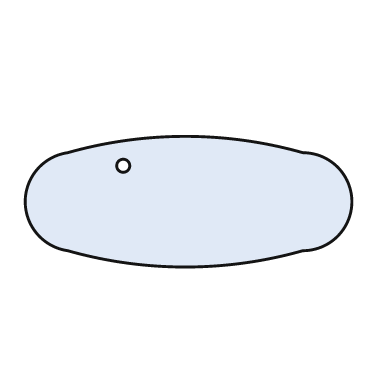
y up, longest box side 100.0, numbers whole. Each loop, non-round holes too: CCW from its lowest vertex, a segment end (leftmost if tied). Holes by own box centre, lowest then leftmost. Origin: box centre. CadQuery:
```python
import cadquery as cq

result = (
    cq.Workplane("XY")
    .moveTo(-37.0, -15.0)
    .threePointArc((-1.0, -20.0), (35.0, -15.0))
    .threePointArc((50.0, 0.0), (35.0, 15.0))
    .threePointArc((-1.0, 20.0), (-37.0, 15.0))
    .threePointArc((-50.0, 0.0), (-37.0, -15.0))
    .close()
    .moveTo(-20.0, 11.0)
    .circle(2.0)
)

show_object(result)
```